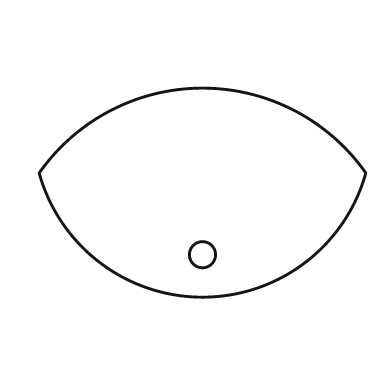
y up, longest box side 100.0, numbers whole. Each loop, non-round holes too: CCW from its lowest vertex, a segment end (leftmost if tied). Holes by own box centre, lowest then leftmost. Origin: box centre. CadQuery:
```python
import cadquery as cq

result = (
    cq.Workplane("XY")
    .moveTo(-50.0, 6.0)
    .threePointArc((0.0, -32.0), (50.0, 6.0))
    .threePointArc((0.0, 32.0), (-50.0, 6.0))
    .close()
    .moveTo(0.0, -19.0)
    .circle(4.0)
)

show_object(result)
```